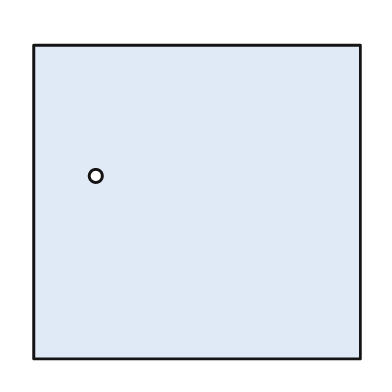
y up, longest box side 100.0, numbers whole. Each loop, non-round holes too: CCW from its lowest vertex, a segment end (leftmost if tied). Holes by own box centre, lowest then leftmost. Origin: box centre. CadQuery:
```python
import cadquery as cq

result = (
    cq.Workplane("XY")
    .moveTo(-50.0, -48.0)
    .lineTo(50.0, -48.0)
    .lineTo(50.0, 48.0)
    .lineTo(-50.0, 48.0)
    .close()
    .moveTo(-31.0, 8.0)
    .circle(2.0)
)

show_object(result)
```